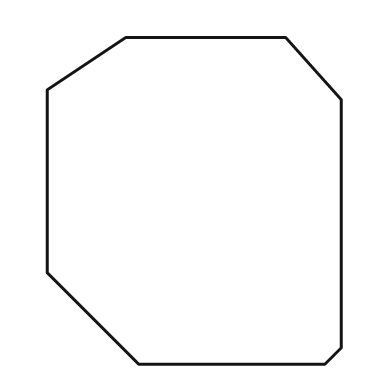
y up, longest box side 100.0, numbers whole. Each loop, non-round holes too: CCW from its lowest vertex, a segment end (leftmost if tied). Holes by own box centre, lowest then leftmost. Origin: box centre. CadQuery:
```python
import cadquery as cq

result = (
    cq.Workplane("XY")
    .moveTo(-17.0, -50.0)
    .lineTo(40.0, -50.0)
    .lineTo(45.0, -45.0)
    .lineTo(45.0, 31.0)
    .lineTo(28.0, 50.0)
    .lineTo(-21.0, 50.0)
    .lineTo(-45.0, 34.0)
    .lineTo(-45.0, -22.0)
    .close()
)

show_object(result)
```